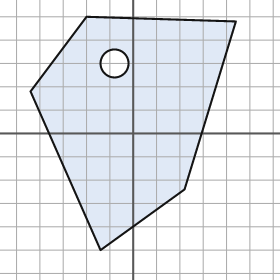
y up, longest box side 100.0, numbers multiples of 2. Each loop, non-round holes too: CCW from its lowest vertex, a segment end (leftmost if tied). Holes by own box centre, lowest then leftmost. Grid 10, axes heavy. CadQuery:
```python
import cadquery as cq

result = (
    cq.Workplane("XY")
    .moveTo(-14.0, -50.0)
    .lineTo(22.0, -24.0)
    .lineTo(44.0, 48.0)
    .lineTo(-20.0, 50.0)
    .lineTo(-44.0, 18.0)
    .close()
    .moveTo(-8.0, 30.0)
    .circle(6.0)
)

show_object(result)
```